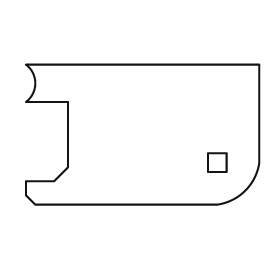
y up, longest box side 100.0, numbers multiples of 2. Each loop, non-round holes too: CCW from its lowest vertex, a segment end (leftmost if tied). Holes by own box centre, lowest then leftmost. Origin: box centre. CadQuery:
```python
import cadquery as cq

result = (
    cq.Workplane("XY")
    .moveTo(-46.0, -30.0)
    .lineTo(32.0, -30.0)
    .threePointArc((44.0, -24.0), (50.0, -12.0))
    .lineTo(50.0, 30.0)
    .lineTo(-50.0, 30.0)
    .threePointArc((-46.0, 22.0), (-50.0, 14.0))
    .lineTo(-32.0, 14.0)
    .lineTo(-32.0, -14.0)
    .lineTo(-38.0, -20.0)
    .lineTo(-50.0, -20.0)
    .lineTo(-50.0, -26.0)
    .close()
    .moveTo(28.0, -16.0)
    .lineTo(36.0, -16.0)
    .lineTo(36.0, -8.0)
    .lineTo(28.0, -8.0)
    .close()
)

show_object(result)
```